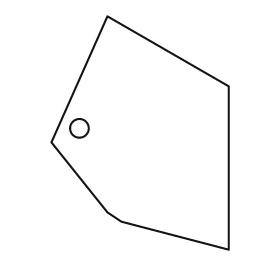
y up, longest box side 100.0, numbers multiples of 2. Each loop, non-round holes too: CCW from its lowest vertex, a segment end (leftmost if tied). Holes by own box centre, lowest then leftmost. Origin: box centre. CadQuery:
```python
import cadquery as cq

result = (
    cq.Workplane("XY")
    .moveTo(38.0, -50.0)
    .lineTo(38.0, 20.0)
    .lineTo(-14.0, 50.0)
    .lineTo(-38.0, -4.0)
    .lineTo(-14.0, -34.0)
    .lineTo(-8.0, -38.0)
    .close()
    .moveTo(-26.0, 2.0)
    .circle(4.0)
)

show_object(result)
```